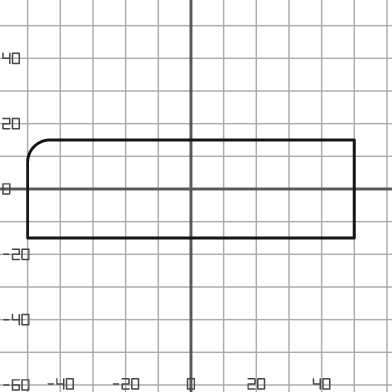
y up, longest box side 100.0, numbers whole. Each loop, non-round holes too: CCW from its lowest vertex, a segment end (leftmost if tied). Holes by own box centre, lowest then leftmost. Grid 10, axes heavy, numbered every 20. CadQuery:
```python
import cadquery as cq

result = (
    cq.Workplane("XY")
    .moveTo(-50.0, -15.0)
    .lineTo(50.0, -15.0)
    .lineTo(50.0, 15.0)
    .lineTo(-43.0, 15.0)
    .threePointArc((-48.0, 13.0), (-50.0, 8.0))
    .close()
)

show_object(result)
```